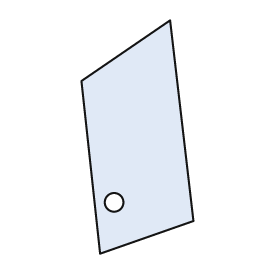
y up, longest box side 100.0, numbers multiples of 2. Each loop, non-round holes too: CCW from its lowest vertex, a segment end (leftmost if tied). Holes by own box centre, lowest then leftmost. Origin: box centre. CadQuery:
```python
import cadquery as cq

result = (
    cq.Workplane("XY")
    .moveTo(-16.0, -50.0)
    .lineTo(24.0, -36.0)
    .lineTo(14.0, 50.0)
    .lineTo(-24.0, 24.0)
    .close()
    .moveTo(-10.0, -28.0)
    .circle(4.0)
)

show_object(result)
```